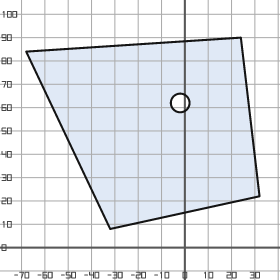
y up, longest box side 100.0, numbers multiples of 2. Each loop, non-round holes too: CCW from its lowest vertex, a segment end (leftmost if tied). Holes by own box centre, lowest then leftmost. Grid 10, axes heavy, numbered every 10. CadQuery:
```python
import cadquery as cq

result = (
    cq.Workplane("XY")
    .moveTo(-32.0, 8.0)
    .lineTo(32.0, 22.0)
    .lineTo(24.0, 90.0)
    .lineTo(-68.0, 84.0)
    .close()
    .moveTo(-2.0, 62.0)
    .circle(4.0)
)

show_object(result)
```